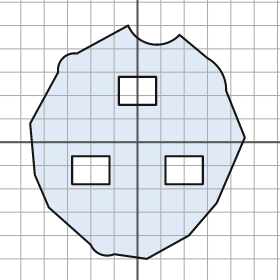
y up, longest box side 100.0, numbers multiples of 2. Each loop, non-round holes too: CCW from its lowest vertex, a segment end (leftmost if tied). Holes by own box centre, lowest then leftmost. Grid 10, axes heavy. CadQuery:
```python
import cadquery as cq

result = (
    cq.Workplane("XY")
    .moveTo(4.0, -50.0)
    .lineTo(22.0, -40.0)
    .lineTo(34.0, -26.0)
    .lineTo(46.0, 2.0)
    .lineTo(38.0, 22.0)
    .threePointArc((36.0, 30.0), (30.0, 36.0))
    .lineTo(18.0, 46.0)
    .threePointArc((6.0, 42.0), (-4.0, 50.0))
    .lineTo(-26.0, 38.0)
    .threePointArc((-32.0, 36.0), (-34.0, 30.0))
    .lineTo(-46.0, 8.0)
    .lineTo(-44.0, -14.0)
    .lineTo(-38.0, -28.0)
    .lineTo(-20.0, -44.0)
    .threePointArc((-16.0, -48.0), (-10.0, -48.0))
    .close()
    .moveTo(-28.0, -18.0)
    .lineTo(-12.0, -18.0)
    .lineTo(-12.0, -6.0)
    .lineTo(-28.0, -6.0)
    .close()
    .moveTo(12.0, -18.0)
    .lineTo(28.0, -18.0)
    .lineTo(28.0, -6.0)
    .lineTo(12.0, -6.0)
    .close()
    .moveTo(-8.0, 16.0)
    .lineTo(8.0, 16.0)
    .lineTo(8.0, 28.0)
    .lineTo(-8.0, 28.0)
    .close()
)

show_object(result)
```